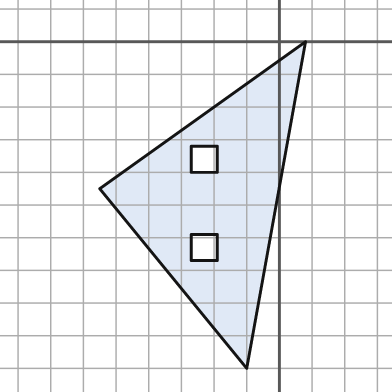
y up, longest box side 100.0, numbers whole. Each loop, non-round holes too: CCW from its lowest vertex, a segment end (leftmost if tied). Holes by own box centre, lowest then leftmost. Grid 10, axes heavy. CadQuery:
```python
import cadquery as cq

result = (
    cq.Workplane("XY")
    .moveTo(-10.0, -100.0)
    .lineTo(8.0, 0.0)
    .lineTo(-55.0, -45.0)
    .close()
    .moveTo(-27.0, -67.0)
    .lineTo(-19.0, -67.0)
    .lineTo(-19.0, -59.0)
    .lineTo(-27.0, -59.0)
    .close()
    .moveTo(-27.0, -40.0)
    .lineTo(-19.0, -40.0)
    .lineTo(-19.0, -32.0)
    .lineTo(-27.0, -32.0)
    .close()
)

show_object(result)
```